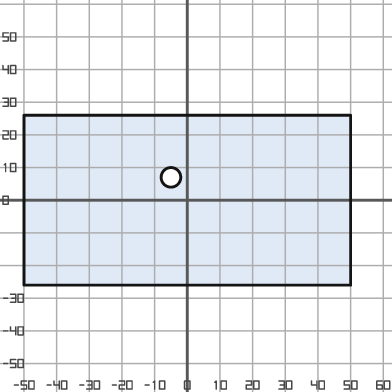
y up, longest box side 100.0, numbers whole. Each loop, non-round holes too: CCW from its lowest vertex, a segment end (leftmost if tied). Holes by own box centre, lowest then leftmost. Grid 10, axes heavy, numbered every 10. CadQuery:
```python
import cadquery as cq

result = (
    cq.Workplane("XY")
    .moveTo(-50.0, -26.0)
    .lineTo(50.0, -26.0)
    .lineTo(50.0, 26.0)
    .lineTo(-50.0, 26.0)
    .close()
    .moveTo(-5.0, 7.0)
    .circle(3.0)
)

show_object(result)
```